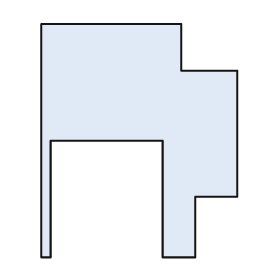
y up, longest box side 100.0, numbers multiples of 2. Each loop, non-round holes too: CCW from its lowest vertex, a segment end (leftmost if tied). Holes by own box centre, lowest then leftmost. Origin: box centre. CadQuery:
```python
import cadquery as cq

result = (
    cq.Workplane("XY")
    .moveTo(-42.0, -50.0)
    .lineTo(-38.0, -50.0)
    .lineTo(-38.0, 0.0)
    .lineTo(10.0, 0.0)
    .lineTo(10.0, -50.0)
    .lineTo(24.0, -50.0)
    .lineTo(24.0, -24.0)
    .lineTo(42.0, -24.0)
    .lineTo(42.0, 30.0)
    .lineTo(18.0, 30.0)
    .lineTo(18.0, 50.0)
    .lineTo(-42.0, 50.0)
    .close()
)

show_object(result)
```